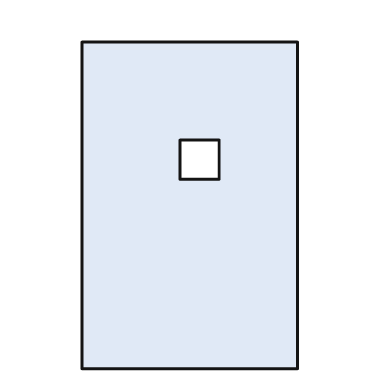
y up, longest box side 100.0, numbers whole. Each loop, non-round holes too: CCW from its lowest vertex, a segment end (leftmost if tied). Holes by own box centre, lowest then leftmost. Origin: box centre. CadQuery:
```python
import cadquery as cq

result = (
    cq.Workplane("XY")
    .moveTo(-33.0, -50.0)
    .lineTo(33.0, -50.0)
    .lineTo(33.0, 50.0)
    .lineTo(-33.0, 50.0)
    .close()
    .moveTo(-3.0, 8.0)
    .lineTo(9.0, 8.0)
    .lineTo(9.0, 20.0)
    .lineTo(-3.0, 20.0)
    .close()
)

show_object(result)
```